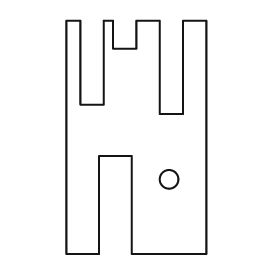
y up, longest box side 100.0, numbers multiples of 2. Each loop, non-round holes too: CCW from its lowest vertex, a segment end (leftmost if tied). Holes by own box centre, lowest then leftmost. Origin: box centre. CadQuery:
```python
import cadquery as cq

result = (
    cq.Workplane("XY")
    .moveTo(-30.0, -50.0)
    .lineTo(-16.0, -50.0)
    .lineTo(-16.0, -8.0)
    .lineTo(-2.0, -8.0)
    .lineTo(-2.0, -50.0)
    .lineTo(30.0, -50.0)
    .lineTo(30.0, 50.0)
    .lineTo(20.0, 50.0)
    .lineTo(20.0, 10.0)
    .lineTo(10.0, 10.0)
    .lineTo(10.0, 50.0)
    .lineTo(0.0, 50.0)
    .lineTo(0.0, 38.0)
    .lineTo(-10.0, 38.0)
    .lineTo(-10.0, 50.0)
    .lineTo(-14.0, 50.0)
    .lineTo(-14.0, 14.0)
    .lineTo(-24.0, 14.0)
    .lineTo(-24.0, 50.0)
    .lineTo(-30.0, 50.0)
    .close()
    .moveTo(14.0, -18.0)
    .circle(4.0)
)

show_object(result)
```